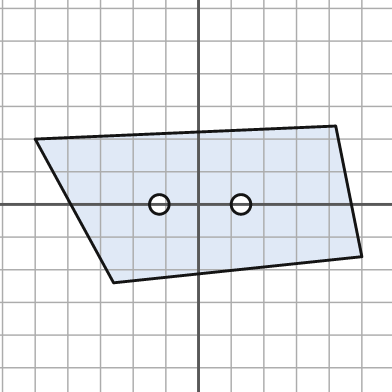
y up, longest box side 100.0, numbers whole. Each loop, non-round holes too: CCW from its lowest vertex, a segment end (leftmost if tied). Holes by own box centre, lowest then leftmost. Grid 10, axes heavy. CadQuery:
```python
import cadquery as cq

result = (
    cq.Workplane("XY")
    .moveTo(-26.0, -24.0)
    .lineTo(50.0, -16.0)
    .lineTo(42.0, 24.0)
    .lineTo(-50.0, 20.0)
    .close()
    .moveTo(-12.0, 0.0)
    .circle(3.0)
    .moveTo(13.0, 0.0)
    .circle(3.0)
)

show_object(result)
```